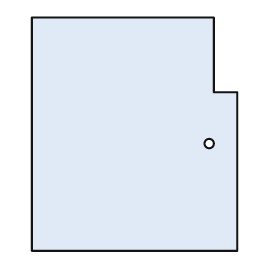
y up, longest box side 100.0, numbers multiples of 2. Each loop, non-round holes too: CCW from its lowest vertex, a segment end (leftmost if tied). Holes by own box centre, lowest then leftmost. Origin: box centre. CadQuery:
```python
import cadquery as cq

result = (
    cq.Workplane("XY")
    .moveTo(-44.0, -50.0)
    .lineTo(44.0, -50.0)
    .lineTo(44.0, 18.0)
    .lineTo(34.0, 18.0)
    .lineTo(34.0, 50.0)
    .lineTo(-44.0, 50.0)
    .close()
    .moveTo(32.0, -4.0)
    .circle(2.0)
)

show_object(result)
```